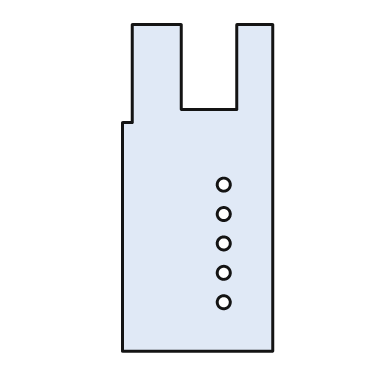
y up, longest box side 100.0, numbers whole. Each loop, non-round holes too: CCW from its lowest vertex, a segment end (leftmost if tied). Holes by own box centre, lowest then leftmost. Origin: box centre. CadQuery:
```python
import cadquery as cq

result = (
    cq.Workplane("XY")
    .moveTo(-23.0, -50.0)
    .lineTo(23.0, -50.0)
    .lineTo(23.0, 50.0)
    .lineTo(12.0, 50.0)
    .lineTo(12.0, 24.0)
    .lineTo(-5.0, 24.0)
    .lineTo(-5.0, 50.0)
    .lineTo(-20.0, 50.0)
    .lineTo(-20.0, 20.0)
    .lineTo(-23.0, 20.0)
    .close()
    .moveTo(8.0, -35.0)
    .circle(2.0)
    .moveTo(8.0, -26.0)
    .circle(2.0)
    .moveTo(8.0, -17.0)
    .circle(2.0)
    .moveTo(8.0, -8.0)
    .circle(2.0)
    .moveTo(8.0, 1.0)
    .circle(2.0)
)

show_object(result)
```